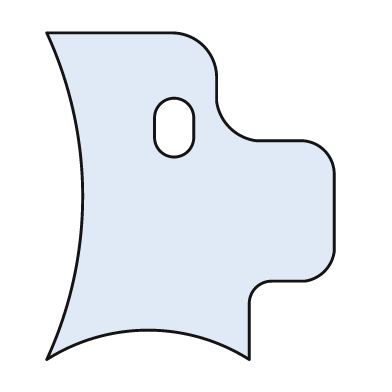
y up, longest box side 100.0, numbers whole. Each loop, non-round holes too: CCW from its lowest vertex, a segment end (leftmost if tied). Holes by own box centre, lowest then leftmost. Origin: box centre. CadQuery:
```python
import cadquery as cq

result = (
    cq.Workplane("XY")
    .moveTo(-44.0, -50.0)
    .threePointArc((-13.0, -41.0), (18.0, -50.0))
    .lineTo(18.0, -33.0)
    .threePointArc((20.0, -28.0), (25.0, -26.0))
    .lineTo(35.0, -26.0)
    .threePointArc((41.0, -23.0), (44.0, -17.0))
    .lineTo(44.0, 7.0)
    .threePointArc((41.0, 14.0), (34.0, 17.0))
    .lineTo(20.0, 17.0)
    .threePointArc((12.0, 21.0), (8.0, 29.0))
    .lineTo(8.0, 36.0)
    .threePointArc((4.0, 46.0), (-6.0, 50.0))
    .lineTo(-44.0, 50.0)
    .threePointArc((-33.0, 0.0), (-44.0, -50.0))
    .close()
    .moveTo(-11.0, 18.0)
    .threePointArc((-5.0, 12.0), (1.0, 18.0))
    .lineTo(1.0, 24.0)
    .threePointArc((-5.0, 30.0), (-11.0, 24.0))
    .close()
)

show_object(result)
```